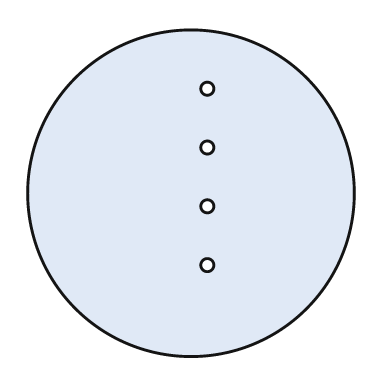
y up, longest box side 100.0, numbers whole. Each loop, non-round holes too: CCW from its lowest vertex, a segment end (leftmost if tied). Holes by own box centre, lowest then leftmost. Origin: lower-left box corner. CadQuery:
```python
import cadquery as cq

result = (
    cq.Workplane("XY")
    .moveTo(50.0, 50.0)
    .circle(50.0)
    .moveTo(55.0, 28.0)
    .circle(2.0)
    .moveTo(55.0, 46.0)
    .circle(2.0)
    .moveTo(55.0, 64.0)
    .circle(2.0)
    .moveTo(55.0, 82.0)
    .circle(2.0)
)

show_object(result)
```